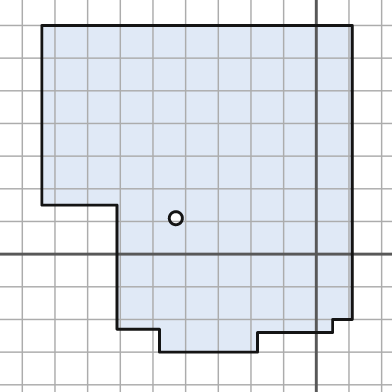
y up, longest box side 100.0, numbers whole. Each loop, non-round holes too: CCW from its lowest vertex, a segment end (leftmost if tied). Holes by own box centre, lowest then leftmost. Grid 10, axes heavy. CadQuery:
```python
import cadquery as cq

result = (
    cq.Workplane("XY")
    .moveTo(-48.0, -30.0)
    .lineTo(-18.0, -30.0)
    .lineTo(-18.0, -24.0)
    .lineTo(5.0, -24.0)
    .lineTo(5.0, -20.0)
    .lineTo(11.0, -20.0)
    .lineTo(11.0, 70.0)
    .lineTo(-84.0, 70.0)
    .lineTo(-84.0, 15.0)
    .lineTo(-61.0, 15.0)
    .lineTo(-61.0, -23.0)
    .lineTo(-48.0, -23.0)
    .close()
    .moveTo(-43.0, 11.0)
    .circle(2.0)
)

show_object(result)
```